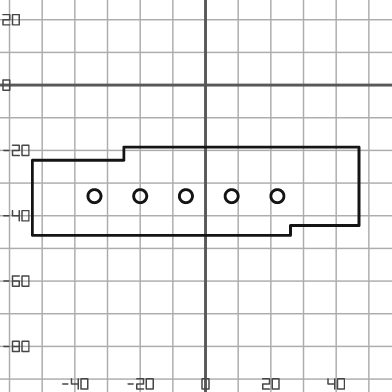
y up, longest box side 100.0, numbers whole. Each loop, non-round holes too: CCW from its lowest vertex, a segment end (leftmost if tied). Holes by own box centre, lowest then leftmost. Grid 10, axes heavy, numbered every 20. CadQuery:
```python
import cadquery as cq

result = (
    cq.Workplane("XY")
    .moveTo(-53.0, -46.0)
    .lineTo(26.0, -46.0)
    .lineTo(26.0, -43.0)
    .lineTo(47.0, -43.0)
    .lineTo(47.0, -19.0)
    .lineTo(-25.0, -19.0)
    .lineTo(-25.0, -23.0)
    .lineTo(-53.0, -23.0)
    .close()
    .moveTo(-34.0, -34.0)
    .circle(2.0)
    .moveTo(-20.0, -34.0)
    .circle(2.0)
    .moveTo(-6.0, -34.0)
    .circle(2.0)
    .moveTo(8.0, -34.0)
    .circle(2.0)
    .moveTo(22.0, -34.0)
    .circle(2.0)
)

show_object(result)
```